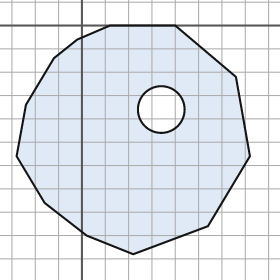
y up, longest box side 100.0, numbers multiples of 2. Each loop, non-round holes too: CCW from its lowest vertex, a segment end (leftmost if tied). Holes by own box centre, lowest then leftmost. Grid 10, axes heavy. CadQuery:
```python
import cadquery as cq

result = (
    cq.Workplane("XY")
    .moveTo(22.0, -98.0)
    .lineTo(54.0, -86.0)
    .lineTo(72.0, -56.0)
    .lineTo(66.0, -22.0)
    .lineTo(40.0, 0.0)
    .lineTo(12.0, 0.0)
    .lineTo(-2.0, -6.0)
    .lineTo(-12.0, -14.0)
    .lineTo(-24.0, -34.0)
    .lineTo(-28.0, -56.0)
    .lineTo(-16.0, -76.0)
    .lineTo(2.0, -90.0)
    .close()
    .moveTo(34.0, -36.0)
    .circle(10.0)
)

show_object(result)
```